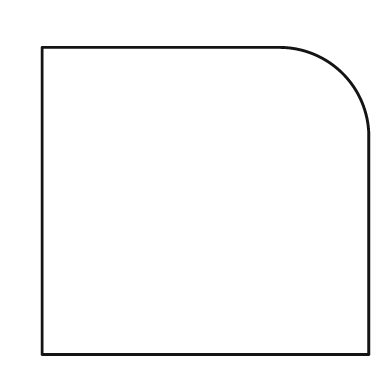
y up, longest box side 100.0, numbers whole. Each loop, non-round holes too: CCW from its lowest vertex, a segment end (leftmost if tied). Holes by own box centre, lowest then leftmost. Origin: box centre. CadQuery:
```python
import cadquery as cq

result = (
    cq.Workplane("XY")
    .moveTo(-50.0, -47.0)
    .lineTo(50.0, -47.0)
    .lineTo(50.0, 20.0)
    .threePointArc((42.0, 39.0), (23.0, 47.0))
    .lineTo(-50.0, 47.0)
    .close()
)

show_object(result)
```